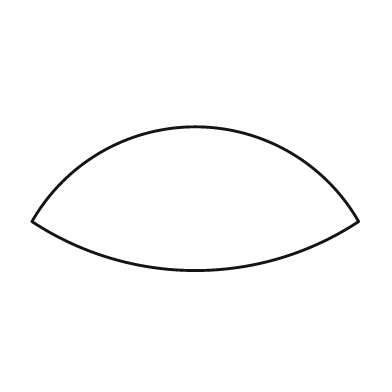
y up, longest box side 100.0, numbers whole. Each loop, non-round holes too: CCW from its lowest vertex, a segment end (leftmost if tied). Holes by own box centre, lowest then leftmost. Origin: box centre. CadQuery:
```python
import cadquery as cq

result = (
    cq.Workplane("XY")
    .moveTo(-50.0, -7.0)
    .threePointArc((0.0, -22.0), (50.0, -7.0))
    .threePointArc((0.0, 22.0), (-50.0, -7.0))
    .close()
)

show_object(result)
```